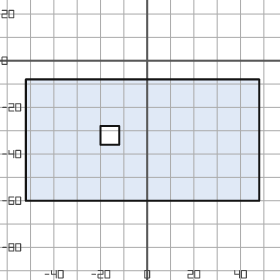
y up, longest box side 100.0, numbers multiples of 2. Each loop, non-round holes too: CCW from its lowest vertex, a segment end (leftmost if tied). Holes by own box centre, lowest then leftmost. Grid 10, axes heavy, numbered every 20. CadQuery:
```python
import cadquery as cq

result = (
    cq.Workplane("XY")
    .moveTo(-52.0, -60.0)
    .lineTo(48.0, -60.0)
    .lineTo(48.0, -8.0)
    .lineTo(-52.0, -8.0)
    .close()
    .moveTo(-20.0, -36.0)
    .lineTo(-12.0, -36.0)
    .lineTo(-12.0, -28.0)
    .lineTo(-20.0, -28.0)
    .close()
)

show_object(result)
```